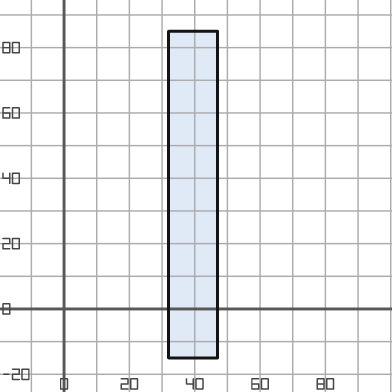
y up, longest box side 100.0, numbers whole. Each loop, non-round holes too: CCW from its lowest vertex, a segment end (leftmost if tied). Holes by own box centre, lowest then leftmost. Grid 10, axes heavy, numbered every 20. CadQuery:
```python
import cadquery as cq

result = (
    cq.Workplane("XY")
    .moveTo(32.0, -15.0)
    .lineTo(47.0, -15.0)
    .lineTo(47.0, 85.0)
    .lineTo(32.0, 85.0)
    .close()
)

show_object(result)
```